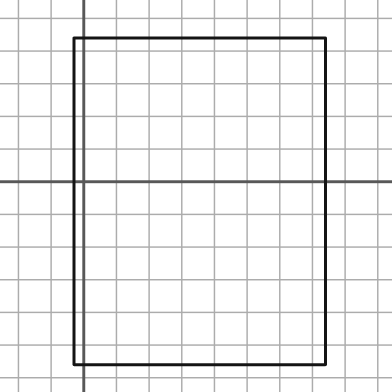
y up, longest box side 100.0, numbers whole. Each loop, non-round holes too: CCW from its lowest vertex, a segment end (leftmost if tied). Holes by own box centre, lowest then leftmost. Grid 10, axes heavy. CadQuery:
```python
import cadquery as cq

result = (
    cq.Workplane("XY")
    .moveTo(-3.0, -56.0)
    .lineTo(74.0, -56.0)
    .lineTo(74.0, 44.0)
    .lineTo(-3.0, 44.0)
    .close()
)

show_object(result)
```